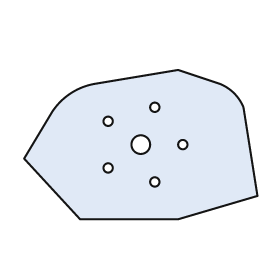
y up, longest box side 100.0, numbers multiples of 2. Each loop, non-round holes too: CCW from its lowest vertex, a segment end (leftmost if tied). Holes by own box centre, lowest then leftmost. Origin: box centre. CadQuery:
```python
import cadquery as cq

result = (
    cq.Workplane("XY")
    .moveTo(-26.0, -32.0)
    .lineTo(16.0, -32.0)
    .lineTo(50.0, -22.0)
    .lineTo(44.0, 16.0)
    .threePointArc((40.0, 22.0), (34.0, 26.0))
    .lineTo(16.0, 32.0)
    .lineTo(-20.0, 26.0)
    .threePointArc((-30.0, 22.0), (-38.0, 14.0))
    .lineTo(-50.0, -6.0)
    .close()
    .moveTo(6.0, -16.0)
    .circle(2.0)
    .moveTo(-14.0, -10.0)
    .circle(2.0)
    .moveTo(0.0, 0.0)
    .circle(4.0)
    .moveTo(18.0, 0.0)
    .circle(2.0)
    .moveTo(-14.0, 10.0)
    .circle(2.0)
    .moveTo(6.0, 16.0)
    .circle(2.0)
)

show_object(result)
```